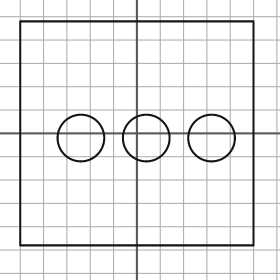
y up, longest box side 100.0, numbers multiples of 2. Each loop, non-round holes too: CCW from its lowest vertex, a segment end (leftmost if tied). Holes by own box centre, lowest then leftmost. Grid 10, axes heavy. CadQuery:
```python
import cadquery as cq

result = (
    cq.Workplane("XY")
    .moveTo(-50.0, -48.0)
    .lineTo(50.0, -48.0)
    .lineTo(50.0, 48.0)
    .lineTo(-50.0, 48.0)
    .close()
    .moveTo(-24.0, -2.0)
    .circle(10.0)
    .moveTo(4.0, -2.0)
    .circle(10.0)
    .moveTo(32.0, -2.0)
    .circle(10.0)
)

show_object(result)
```